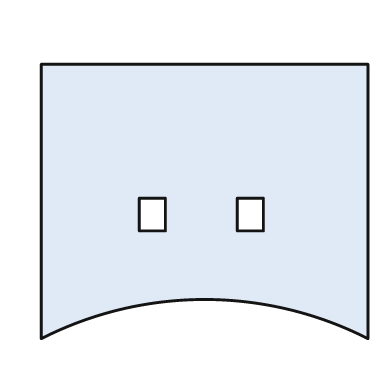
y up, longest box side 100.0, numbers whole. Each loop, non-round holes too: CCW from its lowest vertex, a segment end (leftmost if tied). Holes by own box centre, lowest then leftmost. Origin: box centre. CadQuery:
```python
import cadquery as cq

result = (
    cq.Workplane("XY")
    .moveTo(-50.0, -42.0)
    .threePointArc((0.0, -30.0), (50.0, -42.0))
    .lineTo(50.0, 42.0)
    .lineTo(-50.0, 42.0)
    .close()
    .moveTo(-20.0, -9.0)
    .lineTo(-12.0, -9.0)
    .lineTo(-12.0, 1.0)
    .lineTo(-20.0, 1.0)
    .close()
    .moveTo(10.0, -9.0)
    .lineTo(18.0, -9.0)
    .lineTo(18.0, 1.0)
    .lineTo(10.0, 1.0)
    .close()
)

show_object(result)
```